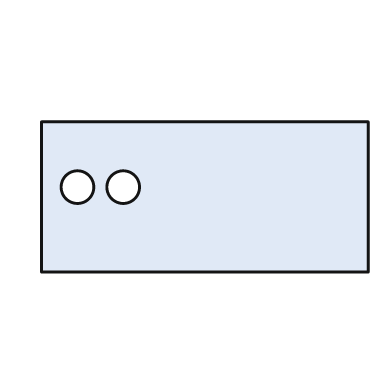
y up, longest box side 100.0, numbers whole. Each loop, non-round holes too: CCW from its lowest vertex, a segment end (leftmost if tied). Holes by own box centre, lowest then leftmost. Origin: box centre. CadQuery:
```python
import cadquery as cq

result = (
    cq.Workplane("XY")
    .moveTo(-50.0, -23.0)
    .lineTo(50.0, -23.0)
    .lineTo(50.0, 23.0)
    .lineTo(-50.0, 23.0)
    .close()
    .moveTo(-39.0, 3.0)
    .circle(5.0)
    .moveTo(-25.0, 3.0)
    .circle(5.0)
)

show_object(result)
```